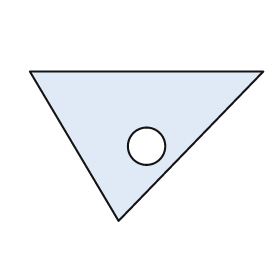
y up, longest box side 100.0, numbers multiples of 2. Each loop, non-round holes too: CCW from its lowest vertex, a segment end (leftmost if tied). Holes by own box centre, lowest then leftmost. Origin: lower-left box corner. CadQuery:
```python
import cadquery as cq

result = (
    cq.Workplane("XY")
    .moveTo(38.0, 0.0)
    .lineTo(100.0, 64.0)
    .lineTo(0.0, 64.0)
    .close()
    .moveTo(50.0, 32.0)
    .circle(8.0)
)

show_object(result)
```